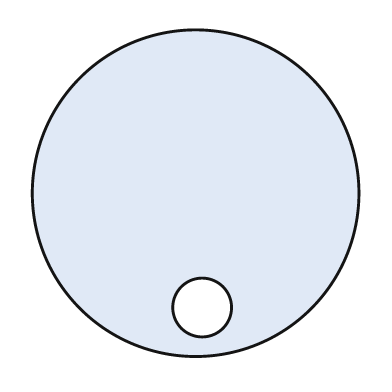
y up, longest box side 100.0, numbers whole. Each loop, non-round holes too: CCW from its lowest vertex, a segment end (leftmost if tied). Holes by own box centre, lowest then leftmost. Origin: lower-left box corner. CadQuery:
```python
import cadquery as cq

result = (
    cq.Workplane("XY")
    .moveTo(50.0, 50.0)
    .circle(50.0)
    .moveTo(52.0, 15.0)
    .circle(9.0)
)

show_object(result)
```